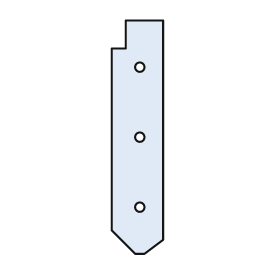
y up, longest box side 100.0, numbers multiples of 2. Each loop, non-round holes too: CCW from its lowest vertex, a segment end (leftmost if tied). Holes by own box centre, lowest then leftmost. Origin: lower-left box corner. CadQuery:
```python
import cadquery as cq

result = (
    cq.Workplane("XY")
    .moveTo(10.0, 0.0)
    .lineTo(14.0, 0.0)
    .lineTo(22.0, 6.0)
    .lineTo(22.0, 100.0)
    .lineTo(6.0, 100.0)
    .lineTo(6.0, 88.0)
    .lineTo(0.0, 88.0)
    .lineTo(0.0, 10.0)
    .close()
    .moveTo(12.0, 20.0)
    .circle(2.0)
    .moveTo(12.0, 50.0)
    .circle(2.0)
    .moveTo(12.0, 80.0)
    .circle(2.0)
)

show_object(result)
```